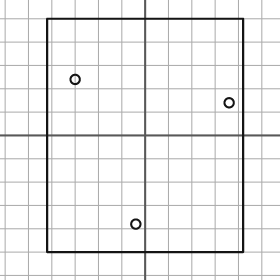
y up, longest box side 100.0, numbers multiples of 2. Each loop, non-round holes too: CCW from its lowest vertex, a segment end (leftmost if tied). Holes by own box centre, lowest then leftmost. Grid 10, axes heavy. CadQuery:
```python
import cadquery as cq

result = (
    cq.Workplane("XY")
    .moveTo(-42.0, -50.0)
    .lineTo(42.0, -50.0)
    .lineTo(42.0, 50.0)
    .lineTo(-42.0, 50.0)
    .close()
    .moveTo(-4.0, -38.0)
    .circle(2.0)
    .moveTo(36.0, 14.0)
    .circle(2.0)
    .moveTo(-30.0, 24.0)
    .circle(2.0)
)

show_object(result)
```